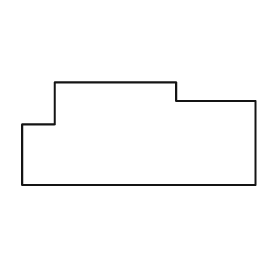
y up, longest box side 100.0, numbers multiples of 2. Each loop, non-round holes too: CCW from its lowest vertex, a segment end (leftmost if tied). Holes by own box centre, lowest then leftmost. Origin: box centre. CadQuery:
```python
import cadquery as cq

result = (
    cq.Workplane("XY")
    .moveTo(-50.0, -22.0)
    .lineTo(50.0, -22.0)
    .lineTo(50.0, 14.0)
    .lineTo(16.0, 14.0)
    .lineTo(16.0, 22.0)
    .lineTo(-36.0, 22.0)
    .lineTo(-36.0, 4.0)
    .lineTo(-50.0, 4.0)
    .close()
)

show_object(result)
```